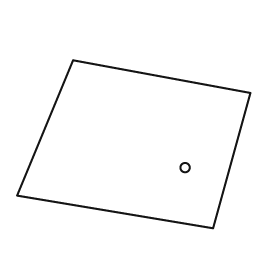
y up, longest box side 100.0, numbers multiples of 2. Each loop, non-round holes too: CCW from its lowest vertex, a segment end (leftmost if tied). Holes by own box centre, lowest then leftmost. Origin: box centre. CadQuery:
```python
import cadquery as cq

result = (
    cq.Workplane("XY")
    .moveTo(34.0, -36.0)
    .lineTo(50.0, 22.0)
    .lineTo(-26.0, 36.0)
    .lineTo(-50.0, -22.0)
    .close()
    .moveTo(22.0, -10.0)
    .circle(2.0)
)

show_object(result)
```